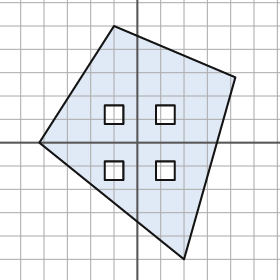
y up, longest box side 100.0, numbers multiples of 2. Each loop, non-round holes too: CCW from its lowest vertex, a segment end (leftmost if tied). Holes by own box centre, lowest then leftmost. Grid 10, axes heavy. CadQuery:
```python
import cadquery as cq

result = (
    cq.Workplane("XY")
    .moveTo(20.0, -50.0)
    .lineTo(42.0, 28.0)
    .lineTo(-10.0, 50.0)
    .lineTo(-42.0, 0.0)
    .close()
    .moveTo(-14.0, -16.0)
    .lineTo(-6.0, -16.0)
    .lineTo(-6.0, -8.0)
    .lineTo(-14.0, -8.0)
    .close()
    .moveTo(8.0, -16.0)
    .lineTo(16.0, -16.0)
    .lineTo(16.0, -8.0)
    .lineTo(8.0, -8.0)
    .close()
    .moveTo(-14.0, 8.0)
    .lineTo(-6.0, 8.0)
    .lineTo(-6.0, 16.0)
    .lineTo(-14.0, 16.0)
    .close()
    .moveTo(8.0, 8.0)
    .lineTo(16.0, 8.0)
    .lineTo(16.0, 16.0)
    .lineTo(8.0, 16.0)
    .close()
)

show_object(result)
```